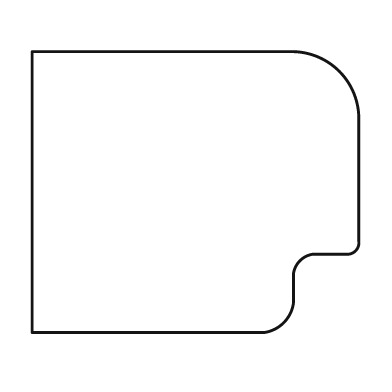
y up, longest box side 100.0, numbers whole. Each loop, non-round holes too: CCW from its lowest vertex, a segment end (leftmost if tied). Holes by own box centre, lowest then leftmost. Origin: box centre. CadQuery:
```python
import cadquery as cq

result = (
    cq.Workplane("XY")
    .moveTo(-50.0, -43.0)
    .lineTo(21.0, -43.0)
    .threePointArc((27.0, -40.0), (30.0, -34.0))
    .lineTo(30.0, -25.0)
    .threePointArc((32.0, -21.0), (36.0, -19.0))
    .lineTo(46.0, -19.0)
    .threePointArc((49.0, -18.0), (50.0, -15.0))
    .lineTo(50.0, 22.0)
    .threePointArc((44.0, 37.0), (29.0, 43.0))
    .lineTo(-50.0, 43.0)
    .close()
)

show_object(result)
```